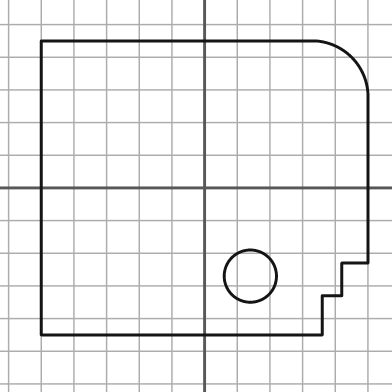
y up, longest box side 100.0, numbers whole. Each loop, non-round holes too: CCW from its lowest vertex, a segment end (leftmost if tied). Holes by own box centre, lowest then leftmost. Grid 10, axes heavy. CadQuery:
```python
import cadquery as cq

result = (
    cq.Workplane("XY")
    .moveTo(-50.0, -45.0)
    .lineTo(36.0, -45.0)
    .lineTo(36.0, -33.0)
    .lineTo(42.0, -33.0)
    .lineTo(42.0, -23.0)
    .lineTo(50.0, -23.0)
    .lineTo(50.0, 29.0)
    .threePointArc((45.0, 40.0), (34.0, 45.0))
    .lineTo(-50.0, 45.0)
    .close()
    .moveTo(14.0, -27.0)
    .circle(8.0)
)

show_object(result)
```